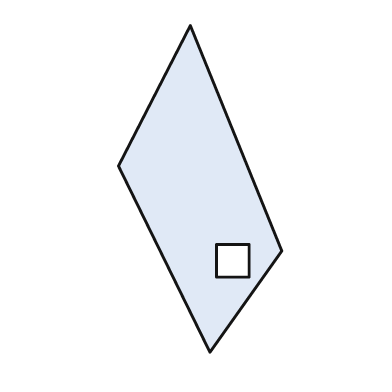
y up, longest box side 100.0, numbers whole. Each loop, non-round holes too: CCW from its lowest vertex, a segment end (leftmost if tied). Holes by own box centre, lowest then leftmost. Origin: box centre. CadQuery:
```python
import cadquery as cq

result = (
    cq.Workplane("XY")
    .moveTo(3.0, -50.0)
    .lineTo(25.0, -19.0)
    .lineTo(-3.0, 50.0)
    .lineTo(-25.0, 7.0)
    .close()
    .moveTo(5.0, -27.0)
    .lineTo(15.0, -27.0)
    .lineTo(15.0, -17.0)
    .lineTo(5.0, -17.0)
    .close()
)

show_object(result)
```